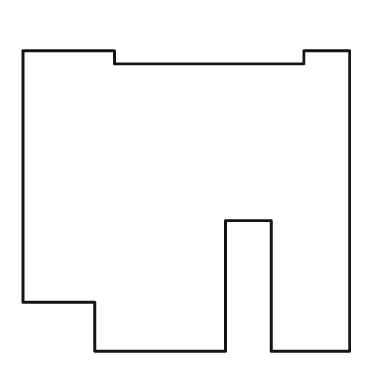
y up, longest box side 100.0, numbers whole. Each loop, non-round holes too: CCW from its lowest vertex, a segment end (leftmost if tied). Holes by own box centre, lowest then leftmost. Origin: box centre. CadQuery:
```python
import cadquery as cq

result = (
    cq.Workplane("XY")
    .moveTo(-28.0, -46.0)
    .lineTo(12.0, -46.0)
    .lineTo(12.0, -6.0)
    .lineTo(26.0, -6.0)
    .lineTo(26.0, -46.0)
    .lineTo(50.0, -46.0)
    .lineTo(50.0, 46.0)
    .lineTo(36.0, 46.0)
    .lineTo(36.0, 42.0)
    .lineTo(-22.0, 42.0)
    .lineTo(-22.0, 46.0)
    .lineTo(-50.0, 46.0)
    .lineTo(-50.0, -31.0)
    .lineTo(-28.0, -31.0)
    .close()
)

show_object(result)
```